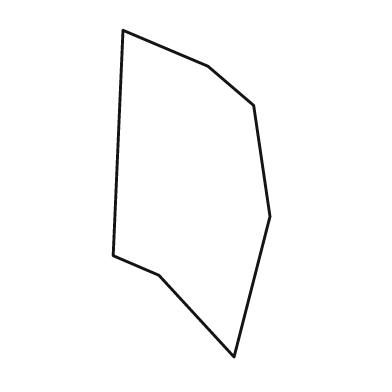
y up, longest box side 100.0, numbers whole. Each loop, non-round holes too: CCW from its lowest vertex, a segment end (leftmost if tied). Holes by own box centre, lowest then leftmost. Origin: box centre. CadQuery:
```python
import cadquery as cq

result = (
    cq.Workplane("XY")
    .moveTo(13.0, -50.0)
    .lineTo(24.0, -7.0)
    .lineTo(19.0, 27.0)
    .lineTo(5.0, 39.0)
    .lineTo(-21.0, 50.0)
    .lineTo(-24.0, -19.0)
    .lineTo(-10.0, -25.0)
    .close()
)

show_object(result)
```